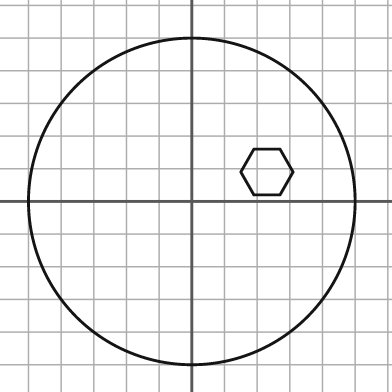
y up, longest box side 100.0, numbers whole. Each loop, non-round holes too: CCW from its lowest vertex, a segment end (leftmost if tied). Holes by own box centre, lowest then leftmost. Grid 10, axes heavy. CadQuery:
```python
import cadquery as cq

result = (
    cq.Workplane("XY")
    .moveTo(0.0, 0.0)
    .circle(50.0)
    .moveTo(19.0, 2.0)
    .lineTo(27.0, 2.0)
    .lineTo(31.0, 9.0)
    .lineTo(27.0, 16.0)
    .lineTo(19.0, 16.0)
    .lineTo(15.0, 9.0)
    .close()
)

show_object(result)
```